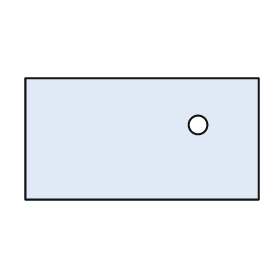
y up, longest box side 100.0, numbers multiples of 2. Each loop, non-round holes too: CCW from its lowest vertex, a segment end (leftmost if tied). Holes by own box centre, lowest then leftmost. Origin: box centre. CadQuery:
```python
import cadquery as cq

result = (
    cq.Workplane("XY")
    .moveTo(-50.0, -26.0)
    .lineTo(50.0, -26.0)
    .lineTo(50.0, 26.0)
    .lineTo(-50.0, 26.0)
    .close()
    .moveTo(24.0, 6.0)
    .circle(4.0)
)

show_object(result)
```